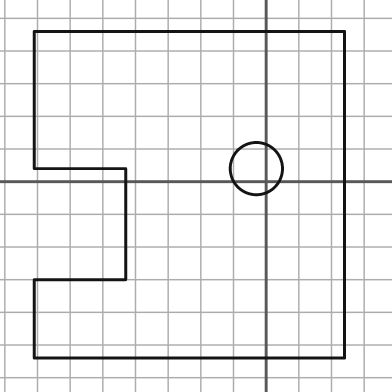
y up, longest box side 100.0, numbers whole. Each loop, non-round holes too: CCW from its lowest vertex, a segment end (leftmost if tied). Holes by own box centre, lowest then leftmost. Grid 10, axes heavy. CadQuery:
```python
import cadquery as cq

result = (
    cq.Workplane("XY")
    .moveTo(-71.0, -54.0)
    .lineTo(24.0, -54.0)
    .lineTo(24.0, 46.0)
    .lineTo(-71.0, 46.0)
    .lineTo(-71.0, 4.0)
    .lineTo(-43.0, 4.0)
    .lineTo(-43.0, -30.0)
    .lineTo(-71.0, -30.0)
    .close()
    .moveTo(-3.0, 4.0)
    .circle(8.0)
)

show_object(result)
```